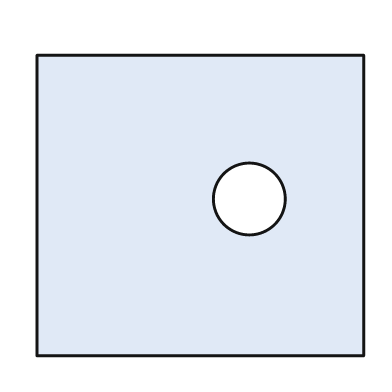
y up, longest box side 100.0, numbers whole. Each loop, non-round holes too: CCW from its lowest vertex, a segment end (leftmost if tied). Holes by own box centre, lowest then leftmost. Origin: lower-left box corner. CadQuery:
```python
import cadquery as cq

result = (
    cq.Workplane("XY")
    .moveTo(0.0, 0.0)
    .lineTo(100.0, 0.0)
    .lineTo(100.0, 92.0)
    .lineTo(0.0, 92.0)
    .close()
    .moveTo(65.0, 48.0)
    .circle(11.0)
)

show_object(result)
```